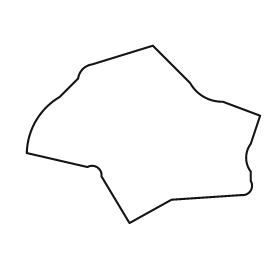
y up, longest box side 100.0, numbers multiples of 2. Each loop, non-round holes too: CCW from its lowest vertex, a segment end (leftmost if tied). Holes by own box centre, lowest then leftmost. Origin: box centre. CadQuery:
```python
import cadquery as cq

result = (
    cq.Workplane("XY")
    .moveTo(-6.0, -38.0)
    .lineTo(12.0, -28.0)
    .lineTo(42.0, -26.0)
    .threePointArc((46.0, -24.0), (46.0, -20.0))
    .lineTo(46.0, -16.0)
    .threePointArc((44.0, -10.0), (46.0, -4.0))
    .lineTo(50.0, 8.0)
    .lineTo(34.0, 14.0)
    .threePointArc((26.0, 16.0), (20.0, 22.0))
    .lineTo(4.0, 38.0)
    .lineTo(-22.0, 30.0)
    .threePointArc((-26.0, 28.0), (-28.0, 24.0))
    .lineTo(-36.0, 16.0)
    .threePointArc((-46.0, 6.0), (-50.0, -8.0))
    .lineTo(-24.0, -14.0)
    .threePointArc((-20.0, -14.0), (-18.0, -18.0))
    .close()
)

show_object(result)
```